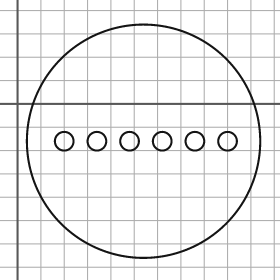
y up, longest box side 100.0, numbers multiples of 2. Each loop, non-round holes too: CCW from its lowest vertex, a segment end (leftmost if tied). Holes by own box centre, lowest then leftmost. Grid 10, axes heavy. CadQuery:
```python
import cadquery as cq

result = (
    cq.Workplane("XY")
    .moveTo(54.0, -16.0)
    .circle(50.0)
    .moveTo(20.0, -16.0)
    .circle(4.0)
    .moveTo(34.0, -16.0)
    .circle(4.0)
    .moveTo(48.0, -16.0)
    .circle(4.0)
    .moveTo(62.0, -16.0)
    .circle(4.0)
    .moveTo(76.0, -16.0)
    .circle(4.0)
    .moveTo(90.0, -16.0)
    .circle(4.0)
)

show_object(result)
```